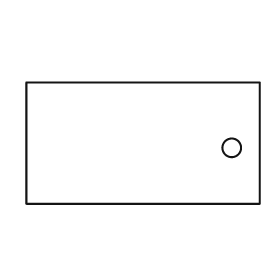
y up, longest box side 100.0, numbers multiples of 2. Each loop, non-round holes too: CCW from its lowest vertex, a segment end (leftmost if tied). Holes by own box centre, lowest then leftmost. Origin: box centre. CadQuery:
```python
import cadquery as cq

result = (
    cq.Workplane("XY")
    .moveTo(-50.0, -26.0)
    .lineTo(50.0, -26.0)
    .lineTo(50.0, 26.0)
    .lineTo(-50.0, 26.0)
    .close()
    .moveTo(38.0, -2.0)
    .circle(4.0)
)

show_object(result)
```